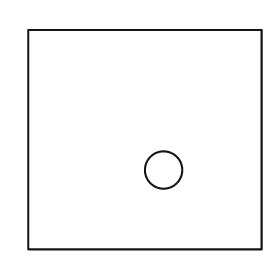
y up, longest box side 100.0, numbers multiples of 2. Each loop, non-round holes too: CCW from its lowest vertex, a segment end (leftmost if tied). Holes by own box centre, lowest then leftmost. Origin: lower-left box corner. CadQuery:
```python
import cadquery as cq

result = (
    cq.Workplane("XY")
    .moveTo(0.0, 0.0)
    .lineTo(100.0, 0.0)
    .lineTo(100.0, 94.0)
    .lineTo(0.0, 94.0)
    .close()
    .moveTo(58.0, 34.0)
    .circle(8.0)
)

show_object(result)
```